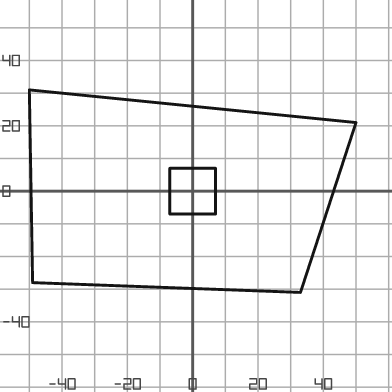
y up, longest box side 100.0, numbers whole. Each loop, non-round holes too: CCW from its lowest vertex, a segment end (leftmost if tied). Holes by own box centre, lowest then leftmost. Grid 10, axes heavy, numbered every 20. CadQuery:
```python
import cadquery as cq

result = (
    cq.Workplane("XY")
    .moveTo(33.0, -31.0)
    .lineTo(50.0, 21.0)
    .lineTo(-50.0, 31.0)
    .lineTo(-49.0, -28.0)
    .close()
    .moveTo(-7.0, -7.0)
    .lineTo(7.0, -7.0)
    .lineTo(7.0, 7.0)
    .lineTo(-7.0, 7.0)
    .close()
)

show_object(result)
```